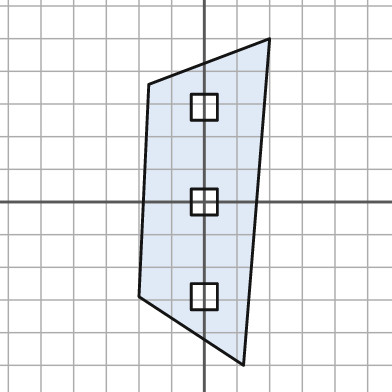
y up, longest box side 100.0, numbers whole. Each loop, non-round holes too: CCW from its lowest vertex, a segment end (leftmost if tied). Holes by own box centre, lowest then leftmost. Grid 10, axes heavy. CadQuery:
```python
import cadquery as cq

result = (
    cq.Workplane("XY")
    .moveTo(12.0, -50.0)
    .lineTo(20.0, 50.0)
    .lineTo(-17.0, 36.0)
    .lineTo(-20.0, -29.0)
    .close()
    .moveTo(-4.0, -33.0)
    .lineTo(4.0, -33.0)
    .lineTo(4.0, -25.0)
    .lineTo(-4.0, -25.0)
    .close()
    .moveTo(-4.0, -4.0)
    .lineTo(4.0, -4.0)
    .lineTo(4.0, 4.0)
    .lineTo(-4.0, 4.0)
    .close()
    .moveTo(-4.0, 25.0)
    .lineTo(4.0, 25.0)
    .lineTo(4.0, 33.0)
    .lineTo(-4.0, 33.0)
    .close()
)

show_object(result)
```